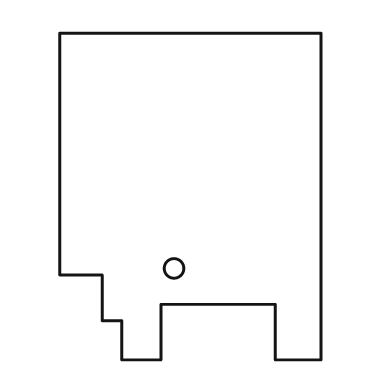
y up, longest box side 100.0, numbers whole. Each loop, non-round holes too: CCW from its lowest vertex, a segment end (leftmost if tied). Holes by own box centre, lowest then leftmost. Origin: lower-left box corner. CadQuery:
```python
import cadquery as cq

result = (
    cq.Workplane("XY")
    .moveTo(19.0, 0.0)
    .lineTo(31.0, 0.0)
    .lineTo(31.0, 17.0)
    .lineTo(66.0, 17.0)
    .lineTo(66.0, 0.0)
    .lineTo(80.0, 0.0)
    .lineTo(80.0, 100.0)
    .lineTo(0.0, 100.0)
    .lineTo(0.0, 26.0)
    .lineTo(13.0, 26.0)
    .lineTo(13.0, 12.0)
    .lineTo(19.0, 12.0)
    .close()
    .moveTo(35.0, 28.0)
    .circle(3.0)
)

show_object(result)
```